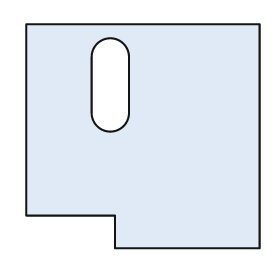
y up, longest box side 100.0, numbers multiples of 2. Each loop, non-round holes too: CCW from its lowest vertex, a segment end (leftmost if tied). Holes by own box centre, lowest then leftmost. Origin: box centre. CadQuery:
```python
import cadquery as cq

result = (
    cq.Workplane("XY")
    .moveTo(-12.0, -48.0)
    .lineTo(50.0, -48.0)
    .lineTo(50.0, 48.0)
    .lineTo(-50.0, 48.0)
    .lineTo(-50.0, -34.0)
    .lineTo(-12.0, -34.0)
    .close()
    .moveTo(-22.0, 10.0)
    .threePointArc((-14.0, 2.0), (-6.0, 10.0))
    .lineTo(-6.0, 34.0)
    .threePointArc((-14.0, 42.0), (-22.0, 34.0))
    .close()
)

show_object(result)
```